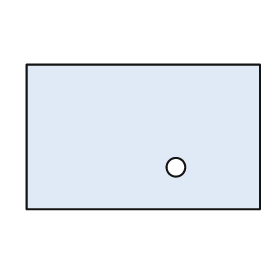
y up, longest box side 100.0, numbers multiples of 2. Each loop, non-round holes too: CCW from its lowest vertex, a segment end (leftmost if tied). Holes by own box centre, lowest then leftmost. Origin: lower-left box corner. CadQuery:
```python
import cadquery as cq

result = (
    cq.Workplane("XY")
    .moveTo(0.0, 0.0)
    .lineTo(100.0, 0.0)
    .lineTo(100.0, 62.0)
    .lineTo(0.0, 62.0)
    .close()
    .moveTo(64.0, 18.0)
    .circle(4.0)
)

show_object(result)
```